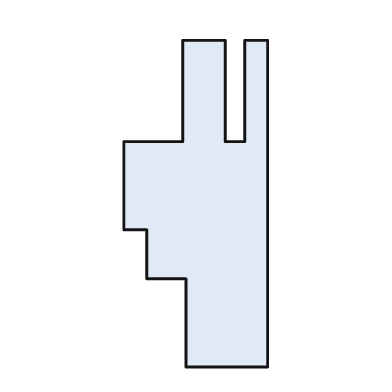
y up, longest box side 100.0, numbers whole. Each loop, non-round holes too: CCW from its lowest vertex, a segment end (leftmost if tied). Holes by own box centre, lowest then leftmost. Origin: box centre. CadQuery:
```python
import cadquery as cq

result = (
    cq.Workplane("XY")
    .moveTo(-3.0, -50.0)
    .lineTo(22.0, -50.0)
    .lineTo(22.0, 50.0)
    .lineTo(15.0, 50.0)
    .lineTo(15.0, 19.0)
    .lineTo(9.0, 19.0)
    .lineTo(9.0, 50.0)
    .lineTo(-4.0, 50.0)
    .lineTo(-4.0, 19.0)
    .lineTo(-22.0, 19.0)
    .lineTo(-22.0, -8.0)
    .lineTo(-15.0, -8.0)
    .lineTo(-15.0, -23.0)
    .lineTo(-3.0, -23.0)
    .close()
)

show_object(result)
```